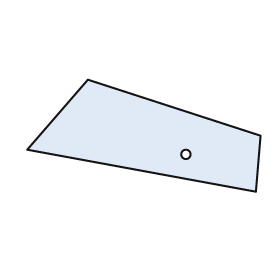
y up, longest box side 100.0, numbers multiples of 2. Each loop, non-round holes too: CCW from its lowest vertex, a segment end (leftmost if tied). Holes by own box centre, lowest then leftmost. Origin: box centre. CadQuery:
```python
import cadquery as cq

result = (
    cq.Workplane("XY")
    .moveTo(48.0, -24.0)
    .lineTo(50.0, 0.0)
    .lineTo(-24.0, 24.0)
    .lineTo(-50.0, -6.0)
    .close()
    .moveTo(18.0, -8.0)
    .circle(2.0)
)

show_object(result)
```